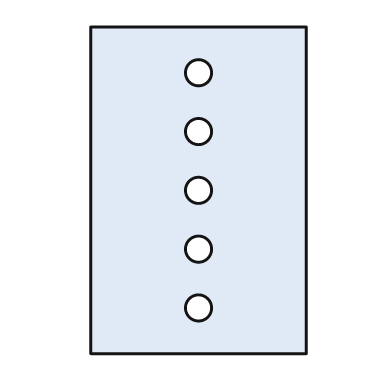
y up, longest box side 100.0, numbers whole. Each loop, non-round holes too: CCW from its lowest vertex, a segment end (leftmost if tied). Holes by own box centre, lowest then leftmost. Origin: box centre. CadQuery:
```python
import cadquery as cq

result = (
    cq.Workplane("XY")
    .moveTo(-33.0, -50.0)
    .lineTo(33.0, -50.0)
    .lineTo(33.0, 50.0)
    .lineTo(-33.0, 50.0)
    .close()
    .moveTo(0.0, -36.0)
    .circle(4.0)
    .moveTo(0.0, -18.0)
    .circle(4.0)
    .moveTo(0.0, 0.0)
    .circle(4.0)
    .moveTo(0.0, 18.0)
    .circle(4.0)
    .moveTo(0.0, 36.0)
    .circle(4.0)
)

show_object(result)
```